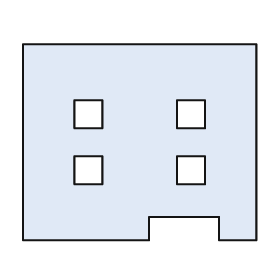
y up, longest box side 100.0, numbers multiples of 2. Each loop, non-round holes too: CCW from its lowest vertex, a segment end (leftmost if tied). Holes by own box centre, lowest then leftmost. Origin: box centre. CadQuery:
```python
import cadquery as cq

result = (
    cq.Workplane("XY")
    .moveTo(-50.0, -42.0)
    .lineTo(4.0, -42.0)
    .lineTo(4.0, -32.0)
    .lineTo(34.0, -32.0)
    .lineTo(34.0, -42.0)
    .lineTo(50.0, -42.0)
    .lineTo(50.0, 42.0)
    .lineTo(-50.0, 42.0)
    .close()
    .moveTo(-28.0, -18.0)
    .lineTo(-16.0, -18.0)
    .lineTo(-16.0, -6.0)
    .lineTo(-28.0, -6.0)
    .close()
    .moveTo(16.0, -18.0)
    .lineTo(28.0, -18.0)
    .lineTo(28.0, -6.0)
    .lineTo(16.0, -6.0)
    .close()
    .moveTo(-28.0, 6.0)
    .lineTo(-16.0, 6.0)
    .lineTo(-16.0, 18.0)
    .lineTo(-28.0, 18.0)
    .close()
    .moveTo(16.0, 6.0)
    .lineTo(28.0, 6.0)
    .lineTo(28.0, 18.0)
    .lineTo(16.0, 18.0)
    .close()
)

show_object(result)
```